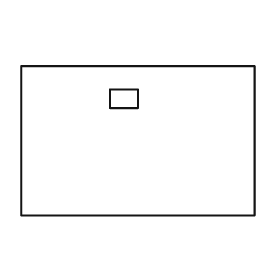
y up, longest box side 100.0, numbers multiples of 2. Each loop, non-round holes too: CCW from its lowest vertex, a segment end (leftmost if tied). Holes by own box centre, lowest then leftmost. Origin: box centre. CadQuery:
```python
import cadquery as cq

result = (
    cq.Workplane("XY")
    .moveTo(-50.0, -32.0)
    .lineTo(50.0, -32.0)
    .lineTo(50.0, 32.0)
    .lineTo(-50.0, 32.0)
    .close()
    .moveTo(-12.0, 14.0)
    .lineTo(0.0, 14.0)
    .lineTo(0.0, 22.0)
    .lineTo(-12.0, 22.0)
    .close()
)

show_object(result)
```